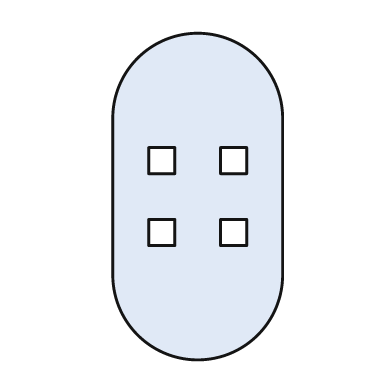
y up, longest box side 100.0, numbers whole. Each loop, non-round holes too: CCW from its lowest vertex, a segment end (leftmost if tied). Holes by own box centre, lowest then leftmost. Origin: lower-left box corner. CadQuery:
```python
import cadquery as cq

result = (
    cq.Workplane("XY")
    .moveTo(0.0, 26.0)
    .threePointArc((26.0, 0.0), (52.0, 26.0))
    .lineTo(52.0, 74.0)
    .threePointArc((26.0, 100.0), (0.0, 74.0))
    .close()
    .moveTo(11.0, 35.0)
    .lineTo(19.0, 35.0)
    .lineTo(19.0, 43.0)
    .lineTo(11.0, 43.0)
    .close()
    .moveTo(33.0, 35.0)
    .lineTo(41.0, 35.0)
    .lineTo(41.0, 43.0)
    .lineTo(33.0, 43.0)
    .close()
    .moveTo(11.0, 57.0)
    .lineTo(19.0, 57.0)
    .lineTo(19.0, 65.0)
    .lineTo(11.0, 65.0)
    .close()
    .moveTo(33.0, 57.0)
    .lineTo(41.0, 57.0)
    .lineTo(41.0, 65.0)
    .lineTo(33.0, 65.0)
    .close()
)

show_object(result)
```